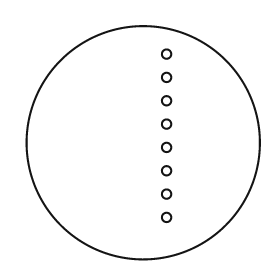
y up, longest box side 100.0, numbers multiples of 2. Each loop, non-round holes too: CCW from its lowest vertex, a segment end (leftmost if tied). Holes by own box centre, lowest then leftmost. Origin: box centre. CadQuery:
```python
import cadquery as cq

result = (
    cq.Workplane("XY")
    .moveTo(0.0, 0.0)
    .circle(50.0)
    .moveTo(10.0, -32.0)
    .circle(2.0)
    .moveTo(10.0, -22.0)
    .circle(2.0)
    .moveTo(10.0, -12.0)
    .circle(2.0)
    .moveTo(10.0, -2.0)
    .circle(2.0)
    .moveTo(10.0, 8.0)
    .circle(2.0)
    .moveTo(10.0, 18.0)
    .circle(2.0)
    .moveTo(10.0, 28.0)
    .circle(2.0)
    .moveTo(10.0, 38.0)
    .circle(2.0)
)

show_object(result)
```